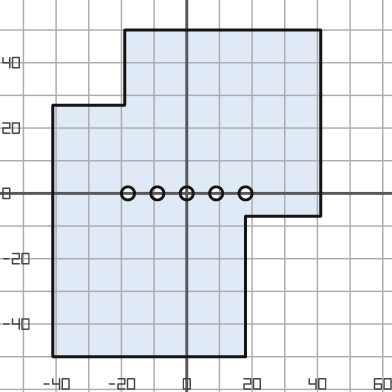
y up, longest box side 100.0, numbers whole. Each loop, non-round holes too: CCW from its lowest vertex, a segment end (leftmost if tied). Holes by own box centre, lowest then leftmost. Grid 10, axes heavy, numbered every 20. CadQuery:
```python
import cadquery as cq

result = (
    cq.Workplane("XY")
    .moveTo(-41.0, -50.0)
    .lineTo(18.0, -50.0)
    .lineTo(18.0, -7.0)
    .lineTo(41.0, -7.0)
    .lineTo(41.0, 50.0)
    .lineTo(-19.0, 50.0)
    .lineTo(-19.0, 27.0)
    .lineTo(-41.0, 27.0)
    .close()
    .moveTo(-18.0, 0.0)
    .circle(2.0)
    .moveTo(-9.0, 0.0)
    .circle(2.0)
    .moveTo(0.0, 0.0)
    .circle(2.0)
    .moveTo(9.0, 0.0)
    .circle(2.0)
    .moveTo(18.0, 0.0)
    .circle(2.0)
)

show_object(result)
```